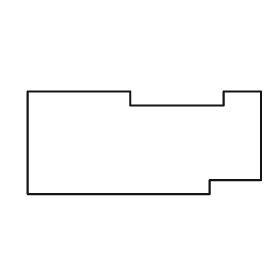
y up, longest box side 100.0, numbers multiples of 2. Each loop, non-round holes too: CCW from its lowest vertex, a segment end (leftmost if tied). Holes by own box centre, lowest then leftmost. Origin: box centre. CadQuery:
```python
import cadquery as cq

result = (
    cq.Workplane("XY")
    .moveTo(-50.0, -22.0)
    .lineTo(28.0, -22.0)
    .lineTo(28.0, -16.0)
    .lineTo(50.0, -16.0)
    .lineTo(50.0, 22.0)
    .lineTo(34.0, 22.0)
    .lineTo(34.0, 16.0)
    .lineTo(-6.0, 16.0)
    .lineTo(-6.0, 22.0)
    .lineTo(-50.0, 22.0)
    .close()
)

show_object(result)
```